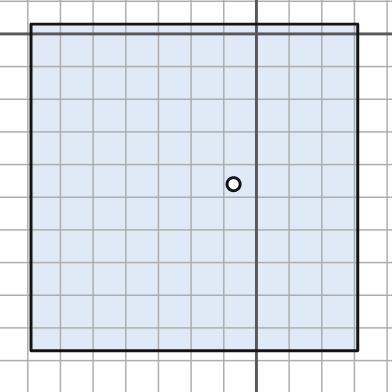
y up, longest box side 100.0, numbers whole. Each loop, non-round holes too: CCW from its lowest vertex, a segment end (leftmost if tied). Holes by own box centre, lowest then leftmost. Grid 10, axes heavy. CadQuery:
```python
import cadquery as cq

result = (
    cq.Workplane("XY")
    .moveTo(-69.0, -97.0)
    .lineTo(31.0, -97.0)
    .lineTo(31.0, 3.0)
    .lineTo(-69.0, 3.0)
    .close()
    .moveTo(-7.0, -46.0)
    .circle(2.0)
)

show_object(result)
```